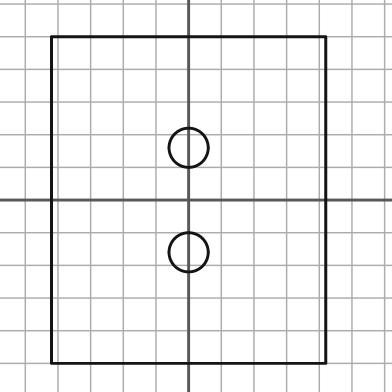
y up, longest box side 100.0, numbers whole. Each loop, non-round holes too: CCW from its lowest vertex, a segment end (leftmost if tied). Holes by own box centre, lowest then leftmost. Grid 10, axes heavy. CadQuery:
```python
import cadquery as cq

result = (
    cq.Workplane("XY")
    .moveTo(-42.0, -50.0)
    .lineTo(42.0, -50.0)
    .lineTo(42.0, 50.0)
    .lineTo(-42.0, 50.0)
    .close()
    .moveTo(0.0, -16.0)
    .circle(6.0)
    .moveTo(0.0, 16.0)
    .circle(6.0)
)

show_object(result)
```